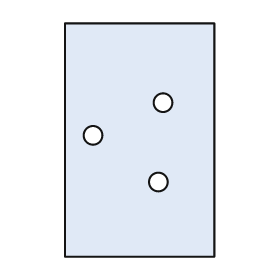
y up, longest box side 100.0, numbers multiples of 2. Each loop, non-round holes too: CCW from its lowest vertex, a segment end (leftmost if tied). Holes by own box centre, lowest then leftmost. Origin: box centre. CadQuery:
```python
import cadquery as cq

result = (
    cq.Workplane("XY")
    .moveTo(-32.0, -50.0)
    .lineTo(32.0, -50.0)
    .lineTo(32.0, 50.0)
    .lineTo(-32.0, 50.0)
    .close()
    .moveTo(8.0, -18.0)
    .circle(4.0)
    .moveTo(-20.0, 2.0)
    .circle(4.0)
    .moveTo(10.0, 16.0)
    .circle(4.0)
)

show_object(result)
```